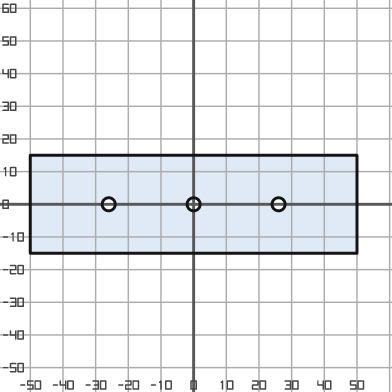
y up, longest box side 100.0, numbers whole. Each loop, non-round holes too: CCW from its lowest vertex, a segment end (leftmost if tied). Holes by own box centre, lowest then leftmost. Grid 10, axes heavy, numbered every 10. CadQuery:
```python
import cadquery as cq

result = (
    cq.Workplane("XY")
    .moveTo(-50.0, -15.0)
    .lineTo(50.0, -15.0)
    .lineTo(50.0, 15.0)
    .lineTo(-50.0, 15.0)
    .close()
    .moveTo(-26.0, 0.0)
    .circle(2.0)
    .moveTo(0.0, 0.0)
    .circle(2.0)
    .moveTo(26.0, 0.0)
    .circle(2.0)
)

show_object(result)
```